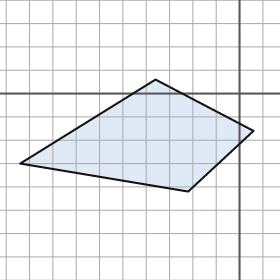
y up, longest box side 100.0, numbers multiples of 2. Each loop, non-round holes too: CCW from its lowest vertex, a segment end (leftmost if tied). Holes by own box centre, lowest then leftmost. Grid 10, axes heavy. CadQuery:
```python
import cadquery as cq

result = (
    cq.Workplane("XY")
    .moveTo(-22.0, -42.0)
    .lineTo(6.0, -16.0)
    .lineTo(-36.0, 6.0)
    .lineTo(-94.0, -30.0)
    .close()
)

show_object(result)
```